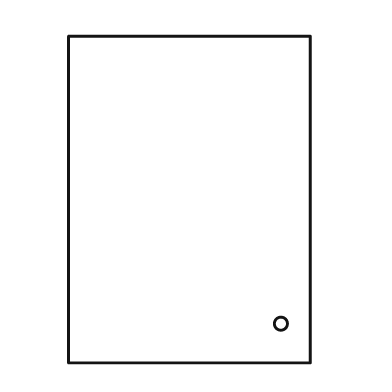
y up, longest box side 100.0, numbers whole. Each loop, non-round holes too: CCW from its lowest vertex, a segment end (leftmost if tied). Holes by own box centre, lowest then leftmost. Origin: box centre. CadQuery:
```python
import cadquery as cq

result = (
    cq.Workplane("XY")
    .moveTo(-37.0, -50.0)
    .lineTo(37.0, -50.0)
    .lineTo(37.0, 50.0)
    .lineTo(-37.0, 50.0)
    .close()
    .moveTo(28.0, -38.0)
    .circle(2.0)
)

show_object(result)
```